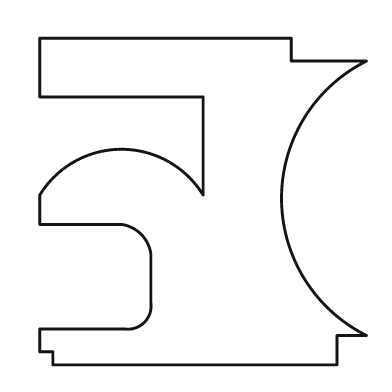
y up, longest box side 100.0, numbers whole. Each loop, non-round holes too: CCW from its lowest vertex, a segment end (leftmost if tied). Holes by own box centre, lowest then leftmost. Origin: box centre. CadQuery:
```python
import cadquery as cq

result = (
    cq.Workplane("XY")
    .moveTo(-46.0, -50.0)
    .lineTo(41.0, -50.0)
    .lineTo(41.0, -41.0)
    .lineTo(50.0, -41.0)
    .threePointArc((24.0, 1.0), (50.0, 43.0))
    .lineTo(27.0, 43.0)
    .lineTo(27.0, 50.0)
    .lineTo(-50.0, 50.0)
    .lineTo(-50.0, 32.0)
    .lineTo(0.0, 32.0)
    .lineTo(0.0, 2.0)
    .threePointArc((-25.0, 16.0), (-50.0, 2.0))
    .lineTo(-50.0, -7.0)
    .lineTo(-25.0, -7.0)
    .threePointArc((-19.0, -10.0), (-16.0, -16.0))
    .lineTo(-16.0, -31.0)
    .threePointArc((-18.0, -37.0), (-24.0, -39.0))
    .lineTo(-50.0, -39.0)
    .lineTo(-50.0, -46.0)
    .lineTo(-46.0, -46.0)
    .close()
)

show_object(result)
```